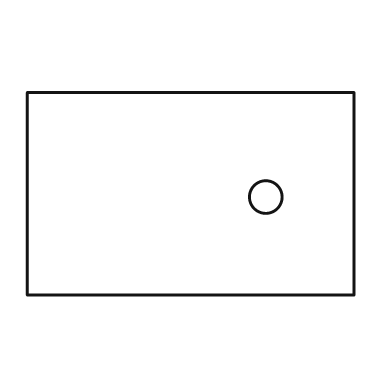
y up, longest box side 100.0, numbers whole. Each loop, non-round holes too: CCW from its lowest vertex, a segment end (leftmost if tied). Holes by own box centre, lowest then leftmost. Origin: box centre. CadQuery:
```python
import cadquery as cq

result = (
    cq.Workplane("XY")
    .moveTo(-50.0, -31.0)
    .lineTo(50.0, -31.0)
    .lineTo(50.0, 31.0)
    .lineTo(-50.0, 31.0)
    .close()
    .moveTo(23.0, -1.0)
    .circle(5.0)
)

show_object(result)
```